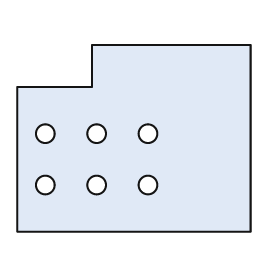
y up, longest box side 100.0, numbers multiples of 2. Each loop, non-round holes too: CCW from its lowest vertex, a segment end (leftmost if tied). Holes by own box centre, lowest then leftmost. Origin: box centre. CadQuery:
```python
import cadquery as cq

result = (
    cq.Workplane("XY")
    .moveTo(-50.0, -40.0)
    .lineTo(50.0, -40.0)
    .lineTo(50.0, 40.0)
    .lineTo(-18.0, 40.0)
    .lineTo(-18.0, 22.0)
    .lineTo(-50.0, 22.0)
    .close()
    .moveTo(-38.0, -20.0)
    .circle(4.0)
    .moveTo(-16.0, -20.0)
    .circle(4.0)
    .moveTo(6.0, -20.0)
    .circle(4.0)
    .moveTo(-38.0, 2.0)
    .circle(4.0)
    .moveTo(-16.0, 2.0)
    .circle(4.0)
    .moveTo(6.0, 2.0)
    .circle(4.0)
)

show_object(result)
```